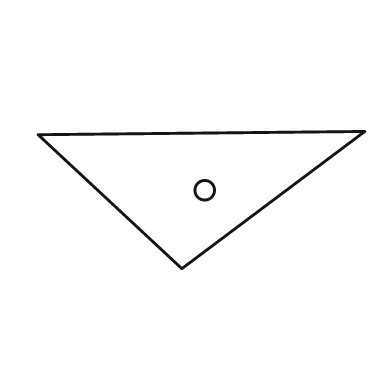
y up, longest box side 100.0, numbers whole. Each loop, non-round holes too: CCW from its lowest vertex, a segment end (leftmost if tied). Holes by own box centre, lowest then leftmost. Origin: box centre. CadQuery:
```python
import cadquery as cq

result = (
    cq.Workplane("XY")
    .moveTo(-6.0, -21.0)
    .lineTo(50.0, 21.0)
    .lineTo(-50.0, 20.0)
    .close()
    .moveTo(1.0, 3.0)
    .circle(3.0)
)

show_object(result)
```